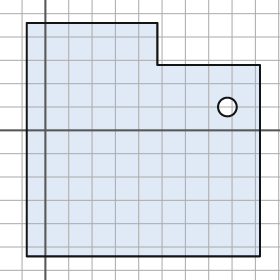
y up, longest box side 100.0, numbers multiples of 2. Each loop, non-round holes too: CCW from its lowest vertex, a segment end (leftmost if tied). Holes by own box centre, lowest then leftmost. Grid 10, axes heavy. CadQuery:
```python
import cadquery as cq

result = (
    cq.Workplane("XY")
    .moveTo(-8.0, -54.0)
    .lineTo(92.0, -54.0)
    .lineTo(92.0, 28.0)
    .lineTo(48.0, 28.0)
    .lineTo(48.0, 46.0)
    .lineTo(-8.0, 46.0)
    .close()
    .moveTo(78.0, 10.0)
    .circle(4.0)
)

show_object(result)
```